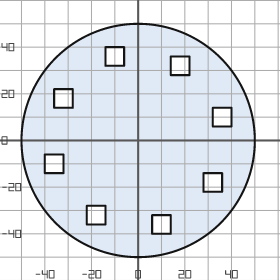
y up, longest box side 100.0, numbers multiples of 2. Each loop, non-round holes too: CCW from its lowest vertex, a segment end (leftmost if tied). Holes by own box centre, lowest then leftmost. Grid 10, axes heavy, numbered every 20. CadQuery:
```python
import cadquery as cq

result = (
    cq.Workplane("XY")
    .moveTo(0.0, 0.0)
    .circle(50.0)
    .moveTo(6.0, -40.0)
    .lineTo(14.0, -40.0)
    .lineTo(14.0, -32.0)
    .lineTo(6.0, -32.0)
    .close()
    .moveTo(-22.0, -36.0)
    .lineTo(-14.0, -36.0)
    .lineTo(-14.0, -28.0)
    .lineTo(-22.0, -28.0)
    .close()
    .moveTo(28.0, -22.0)
    .lineTo(36.0, -22.0)
    .lineTo(36.0, -14.0)
    .lineTo(28.0, -14.0)
    .close()
    .moveTo(-40.0, -14.0)
    .lineTo(-32.0, -14.0)
    .lineTo(-32.0, -6.0)
    .lineTo(-40.0, -6.0)
    .close()
    .moveTo(32.0, 6.0)
    .lineTo(40.0, 6.0)
    .lineTo(40.0, 14.0)
    .lineTo(32.0, 14.0)
    .close()
    .moveTo(-36.0, 14.0)
    .lineTo(-28.0, 14.0)
    .lineTo(-28.0, 22.0)
    .lineTo(-36.0, 22.0)
    .close()
    .moveTo(14.0, 28.0)
    .lineTo(22.0, 28.0)
    .lineTo(22.0, 36.0)
    .lineTo(14.0, 36.0)
    .close()
    .moveTo(-14.0, 32.0)
    .lineTo(-6.0, 32.0)
    .lineTo(-6.0, 40.0)
    .lineTo(-14.0, 40.0)
    .close()
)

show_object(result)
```